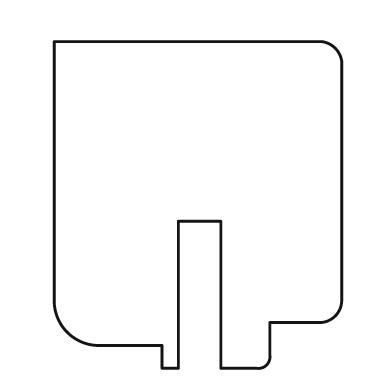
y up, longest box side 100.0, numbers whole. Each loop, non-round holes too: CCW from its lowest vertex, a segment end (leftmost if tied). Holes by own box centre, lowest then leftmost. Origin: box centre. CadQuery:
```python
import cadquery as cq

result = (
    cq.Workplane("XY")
    .moveTo(-11.0, -50.0)
    .lineTo(-6.0, -50.0)
    .lineTo(-6.0, -5.0)
    .lineTo(7.0, -5.0)
    .lineTo(7.0, -50.0)
    .lineTo(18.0, -50.0)
    .threePointArc((21.0, -49.0), (22.0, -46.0))
    .lineTo(22.0, -36.0)
    .lineTo(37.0, -36.0)
    .threePointArc((42.0, -34.0), (44.0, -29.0))
    .lineTo(44.0, 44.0)
    .threePointArc((42.0, 48.0), (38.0, 50.0))
    .lineTo(-44.0, 50.0)
    .lineTo(-44.0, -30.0)
    .threePointArc((-40.0, -39.0), (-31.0, -43.0))
    .lineTo(-11.0, -43.0)
    .close()
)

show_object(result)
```